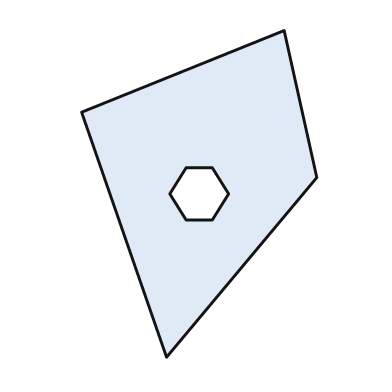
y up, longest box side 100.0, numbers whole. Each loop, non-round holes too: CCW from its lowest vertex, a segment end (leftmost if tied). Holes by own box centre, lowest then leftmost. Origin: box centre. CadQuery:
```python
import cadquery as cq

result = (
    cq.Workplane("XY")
    .moveTo(-10.0, -50.0)
    .lineTo(36.0, 5.0)
    .lineTo(26.0, 50.0)
    .lineTo(-36.0, 25.0)
    .close()
    .moveTo(-4.0, -8.0)
    .lineTo(4.0, -8.0)
    .lineTo(9.0, 0.0)
    .lineTo(4.0, 8.0)
    .lineTo(-4.0, 8.0)
    .lineTo(-9.0, 0.0)
    .close()
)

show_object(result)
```